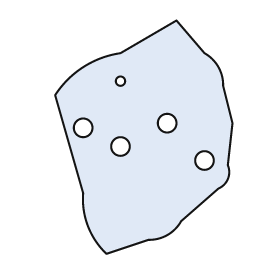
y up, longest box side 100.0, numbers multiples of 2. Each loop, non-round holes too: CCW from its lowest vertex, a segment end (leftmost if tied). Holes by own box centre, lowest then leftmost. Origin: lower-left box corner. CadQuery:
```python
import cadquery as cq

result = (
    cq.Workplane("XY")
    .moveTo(22.0, 0.0)
    .lineTo(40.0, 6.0)
    .threePointArc((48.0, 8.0), (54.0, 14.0))
    .lineTo(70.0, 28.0)
    .threePointArc((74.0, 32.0), (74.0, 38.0))
    .lineTo(76.0, 56.0)
    .lineTo(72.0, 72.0)
    .threePointArc((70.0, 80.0), (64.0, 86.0))
    .lineTo(52.0, 100.0)
    .lineTo(28.0, 86.0)
    .threePointArc((12.0, 80.0), (0.0, 68.0))
    .lineTo(12.0, 26.0)
    .threePointArc((14.0, 12.0), (22.0, 0.0))
    .close()
    .moveTo(64.0, 40.0)
    .circle(4.0)
    .moveTo(28.0, 46.0)
    .circle(4.0)
    .moveTo(12.0, 54.0)
    .circle(4.0)
    .moveTo(48.0, 56.0)
    .circle(4.0)
    .moveTo(28.0, 74.0)
    .circle(2.0)
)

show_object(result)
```